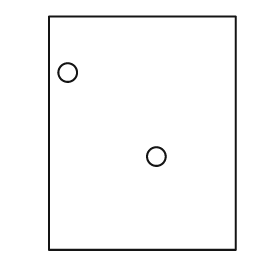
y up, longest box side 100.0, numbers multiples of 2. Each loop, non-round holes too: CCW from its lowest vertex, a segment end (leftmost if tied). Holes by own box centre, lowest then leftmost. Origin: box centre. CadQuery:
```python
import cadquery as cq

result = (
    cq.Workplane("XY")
    .moveTo(-40.0, -50.0)
    .lineTo(40.0, -50.0)
    .lineTo(40.0, 50.0)
    .lineTo(-40.0, 50.0)
    .close()
    .moveTo(6.0, -10.0)
    .circle(4.0)
    .moveTo(-32.0, 26.0)
    .circle(4.0)
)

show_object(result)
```